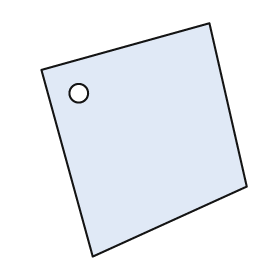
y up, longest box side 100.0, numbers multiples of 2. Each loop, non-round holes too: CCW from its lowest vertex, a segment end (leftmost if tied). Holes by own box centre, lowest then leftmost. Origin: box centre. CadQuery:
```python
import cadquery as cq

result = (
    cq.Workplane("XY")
    .moveTo(-22.0, -50.0)
    .lineTo(44.0, -20.0)
    .lineTo(28.0, 50.0)
    .lineTo(-44.0, 30.0)
    .close()
    .moveTo(-28.0, 20.0)
    .circle(4.0)
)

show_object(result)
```